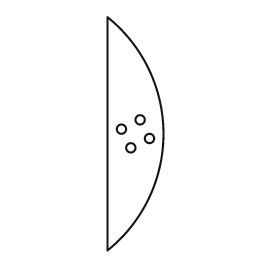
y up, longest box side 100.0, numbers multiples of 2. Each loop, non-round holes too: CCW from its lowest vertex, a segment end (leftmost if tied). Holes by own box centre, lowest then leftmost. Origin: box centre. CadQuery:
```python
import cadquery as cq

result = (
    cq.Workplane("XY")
    .moveTo(-12.0, -50.0)
    .threePointArc((12.0, 0.0), (-12.0, 50.0))
    .close()
    .moveTo(-2.0, -6.0)
    .circle(2.0)
    .moveTo(6.0, -2.0)
    .circle(2.0)
    .moveTo(-6.0, 2.0)
    .circle(2.0)
    .moveTo(2.0, 6.0)
    .circle(2.0)
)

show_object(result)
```